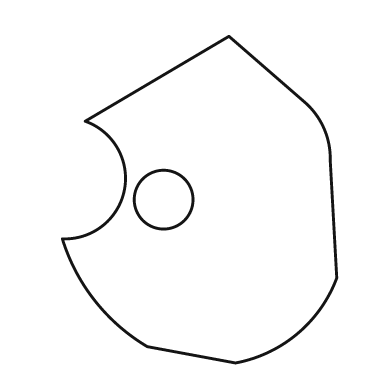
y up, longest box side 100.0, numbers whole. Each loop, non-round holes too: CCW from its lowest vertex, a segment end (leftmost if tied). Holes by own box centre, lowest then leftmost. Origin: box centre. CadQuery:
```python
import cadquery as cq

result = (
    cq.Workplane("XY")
    .moveTo(11.0, -50.0)
    .threePointArc((30.0, -41.0), (42.0, -24.0))
    .lineTo(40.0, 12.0)
    .threePointArc((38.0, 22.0), (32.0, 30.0))
    .lineTo(9.0, 50.0)
    .lineTo(-35.0, 24.0)
    .threePointArc((-23.0, 3.0), (-42.0, -12.0))
    .threePointArc((-32.0, -31.0), (-16.0, -45.0))
    .close()
    .moveTo(-11.0, 0.0)
    .circle(9.0)
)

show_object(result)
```